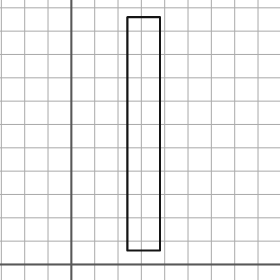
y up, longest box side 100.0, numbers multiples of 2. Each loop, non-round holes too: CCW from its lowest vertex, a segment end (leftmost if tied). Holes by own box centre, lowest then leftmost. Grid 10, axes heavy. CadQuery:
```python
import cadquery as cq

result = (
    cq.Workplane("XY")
    .moveTo(24.0, 6.0)
    .lineTo(38.0, 6.0)
    .lineTo(38.0, 106.0)
    .lineTo(24.0, 106.0)
    .close()
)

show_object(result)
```